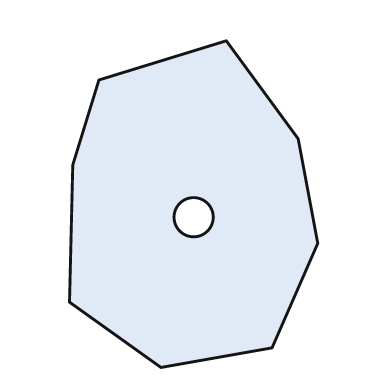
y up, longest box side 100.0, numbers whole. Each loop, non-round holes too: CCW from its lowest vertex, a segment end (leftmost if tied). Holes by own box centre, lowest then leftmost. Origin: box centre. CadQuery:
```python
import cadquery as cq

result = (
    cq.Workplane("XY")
    .moveTo(-10.0, -50.0)
    .lineTo(24.0, -44.0)
    .lineTo(38.0, -12.0)
    .lineTo(32.0, 20.0)
    .lineTo(10.0, 50.0)
    .lineTo(-29.0, 38.0)
    .lineTo(-37.0, 12.0)
    .lineTo(-38.0, -30.0)
    .close()
    .moveTo(0.0, -4.0)
    .circle(6.0)
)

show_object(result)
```